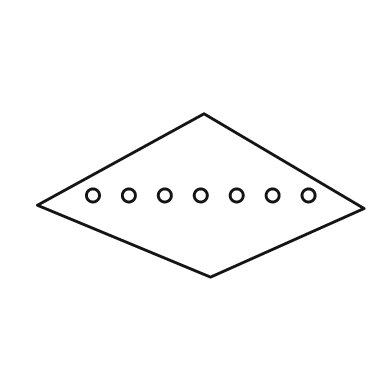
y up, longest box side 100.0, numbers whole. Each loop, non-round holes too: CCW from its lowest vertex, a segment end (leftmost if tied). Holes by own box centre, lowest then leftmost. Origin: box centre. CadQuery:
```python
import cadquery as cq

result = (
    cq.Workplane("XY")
    .moveTo(3.0, -25.0)
    .lineTo(50.0, -4.0)
    .lineTo(1.0, 25.0)
    .lineTo(-50.0, -3.0)
    .close()
    .moveTo(-33.0, 0.0)
    .circle(2.0)
    .moveTo(-22.0, 0.0)
    .circle(2.0)
    .moveTo(-11.0, 0.0)
    .circle(2.0)
    .moveTo(0.0, 0.0)
    .circle(2.0)
    .moveTo(11.0, 0.0)
    .circle(2.0)
    .moveTo(22.0, 0.0)
    .circle(2.0)
    .moveTo(33.0, 0.0)
    .circle(2.0)
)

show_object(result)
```